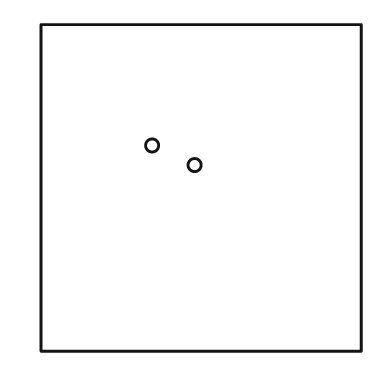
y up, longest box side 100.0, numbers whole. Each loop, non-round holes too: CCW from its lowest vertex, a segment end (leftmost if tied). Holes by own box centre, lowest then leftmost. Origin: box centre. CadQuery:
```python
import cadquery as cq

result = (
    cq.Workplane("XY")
    .moveTo(-49.0, -50.0)
    .lineTo(49.0, -50.0)
    .lineTo(49.0, 50.0)
    .lineTo(-49.0, 50.0)
    .close()
    .moveTo(-2.0, 7.0)
    .circle(2.0)
    .moveTo(-15.0, 13.0)
    .circle(2.0)
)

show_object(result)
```